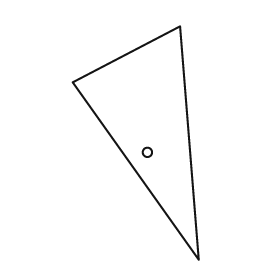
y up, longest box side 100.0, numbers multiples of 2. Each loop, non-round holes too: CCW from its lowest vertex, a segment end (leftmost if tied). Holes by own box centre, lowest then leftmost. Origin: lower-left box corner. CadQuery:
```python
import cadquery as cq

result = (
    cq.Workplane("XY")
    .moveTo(54.0, 0.0)
    .lineTo(46.0, 100.0)
    .lineTo(0.0, 76.0)
    .close()
    .moveTo(32.0, 46.0)
    .circle(2.0)
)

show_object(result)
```